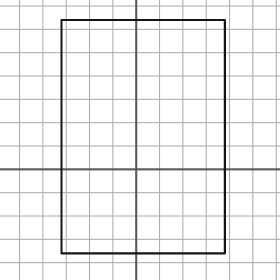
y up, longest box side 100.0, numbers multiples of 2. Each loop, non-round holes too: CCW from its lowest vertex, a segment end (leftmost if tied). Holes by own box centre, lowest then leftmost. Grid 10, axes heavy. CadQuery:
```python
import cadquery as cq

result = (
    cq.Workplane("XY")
    .moveTo(-32.0, -36.0)
    .lineTo(38.0, -36.0)
    .lineTo(38.0, 64.0)
    .lineTo(-32.0, 64.0)
    .close()
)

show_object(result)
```